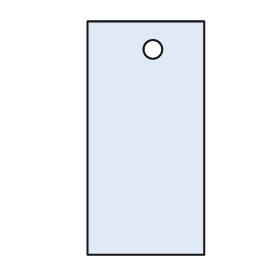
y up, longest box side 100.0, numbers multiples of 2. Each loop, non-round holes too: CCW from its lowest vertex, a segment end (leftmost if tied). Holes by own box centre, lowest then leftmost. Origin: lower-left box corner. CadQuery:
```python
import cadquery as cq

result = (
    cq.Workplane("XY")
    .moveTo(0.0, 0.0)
    .lineTo(50.0, 0.0)
    .lineTo(50.0, 100.0)
    .lineTo(0.0, 100.0)
    .close()
    .moveTo(28.0, 88.0)
    .circle(4.0)
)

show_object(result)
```